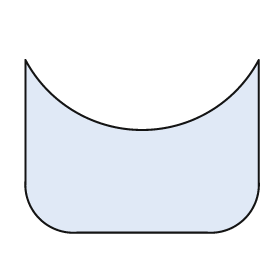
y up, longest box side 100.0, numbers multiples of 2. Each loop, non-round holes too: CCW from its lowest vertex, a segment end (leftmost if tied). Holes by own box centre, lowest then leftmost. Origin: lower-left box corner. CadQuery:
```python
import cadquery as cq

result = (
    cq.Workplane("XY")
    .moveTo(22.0, 0.0)
    .lineTo(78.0, 0.0)
    .threePointArc((94.0, 6.0), (100.0, 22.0))
    .lineTo(100.0, 74.0)
    .threePointArc((50.0, 44.0), (0.0, 74.0))
    .lineTo(0.0, 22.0)
    .threePointArc((6.0, 6.0), (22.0, 0.0))
    .close()
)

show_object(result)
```